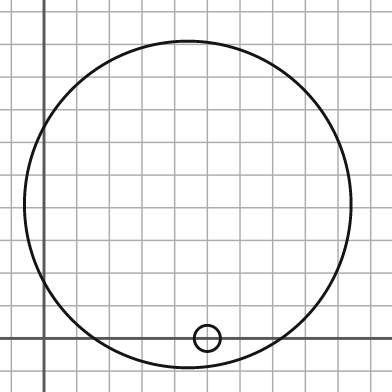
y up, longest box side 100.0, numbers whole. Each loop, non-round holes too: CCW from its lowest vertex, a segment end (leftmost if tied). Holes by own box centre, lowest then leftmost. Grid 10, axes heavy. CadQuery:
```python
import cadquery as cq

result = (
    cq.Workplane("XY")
    .moveTo(44.0, 41.0)
    .circle(50.0)
    .moveTo(50.0, 0.0)
    .circle(4.0)
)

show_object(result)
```